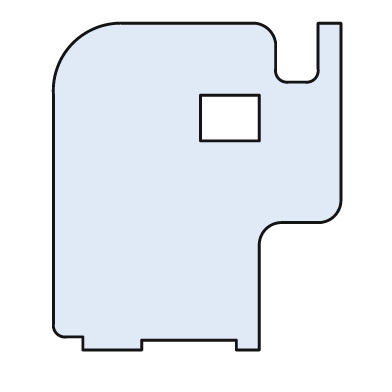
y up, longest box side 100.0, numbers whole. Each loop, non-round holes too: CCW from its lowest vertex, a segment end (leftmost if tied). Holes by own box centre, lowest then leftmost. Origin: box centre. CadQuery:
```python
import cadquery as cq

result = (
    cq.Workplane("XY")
    .moveTo(-35.0, -50.0)
    .lineTo(-17.0, -50.0)
    .lineTo(-17.0, -47.0)
    .lineTo(12.0, -47.0)
    .lineTo(12.0, -50.0)
    .lineTo(19.0, -50.0)
    .lineTo(19.0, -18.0)
    .threePointArc((21.0, -13.0), (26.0, -11.0))
    .lineTo(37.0, -11.0)
    .threePointArc((42.0, -9.0), (44.0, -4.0))
    .lineTo(44.0, 50.0)
    .lineTo(37.0, 50.0)
    .lineTo(37.0, 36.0)
    .threePointArc((36.0, 33.0), (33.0, 32.0))
    .lineTo(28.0, 32.0)
    .threePointArc((25.0, 33.0), (24.0, 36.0))
    .lineTo(24.0, 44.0)
    .threePointArc((22.0, 48.0), (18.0, 50.0))
    .lineTo(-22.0, 50.0)
    .threePointArc((-38.0, 44.0), (-44.0, 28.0))
    .lineTo(-44.0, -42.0)
    .threePointArc((-43.0, -45.0), (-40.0, -46.0))
    .lineTo(-35.0, -46.0)
    .close()
    .moveTo(1.0, 14.0)
    .lineTo(19.0, 14.0)
    .lineTo(19.0, 28.0)
    .lineTo(1.0, 28.0)
    .close()
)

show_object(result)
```